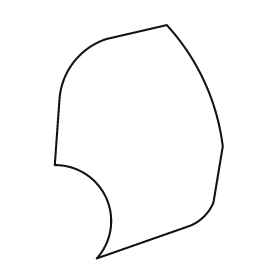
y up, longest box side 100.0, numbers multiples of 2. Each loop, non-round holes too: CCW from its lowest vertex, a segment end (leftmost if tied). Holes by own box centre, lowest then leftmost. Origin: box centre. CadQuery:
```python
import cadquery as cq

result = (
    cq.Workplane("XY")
    .moveTo(-18.0, -50.0)
    .lineTo(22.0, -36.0)
    .threePointArc((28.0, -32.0), (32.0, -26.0))
    .lineTo(36.0, -2.0)
    .threePointArc((28.0, 26.0), (12.0, 50.0))
    .lineTo(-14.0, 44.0)
    .threePointArc((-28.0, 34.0), (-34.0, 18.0))
    .lineTo(-36.0, -10.0)
    .threePointArc((-14.0, -24.0), (-18.0, -50.0))
    .close()
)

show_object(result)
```